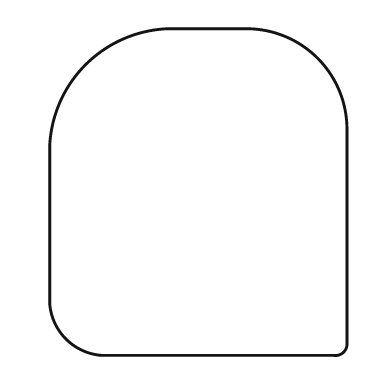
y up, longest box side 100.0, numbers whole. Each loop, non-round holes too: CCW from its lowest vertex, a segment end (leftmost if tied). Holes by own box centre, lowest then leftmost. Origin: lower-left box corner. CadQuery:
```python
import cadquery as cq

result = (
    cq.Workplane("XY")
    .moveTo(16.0, 0.0)
    .lineTo(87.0, 0.0)
    .threePointArc((90.0, 1.0), (91.0, 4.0))
    .lineTo(91.0, 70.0)
    .threePointArc((82.0, 91.0), (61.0, 100.0))
    .lineTo(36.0, 100.0)
    .threePointArc((11.0, 89.0), (0.0, 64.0))
    .lineTo(0.0, 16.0)
    .threePointArc((5.0, 5.0), (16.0, 0.0))
    .close()
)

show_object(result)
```